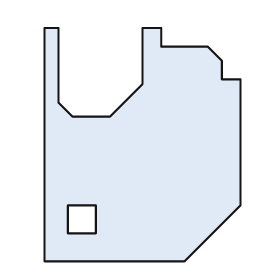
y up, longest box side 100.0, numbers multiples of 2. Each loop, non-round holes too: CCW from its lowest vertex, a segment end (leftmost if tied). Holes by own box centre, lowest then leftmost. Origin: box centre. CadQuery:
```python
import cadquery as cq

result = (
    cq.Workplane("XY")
    .moveTo(-42.0, -50.0)
    .lineTo(18.0, -50.0)
    .lineTo(42.0, -26.0)
    .lineTo(42.0, 28.0)
    .lineTo(34.0, 28.0)
    .lineTo(34.0, 36.0)
    .lineTo(28.0, 42.0)
    .lineTo(8.0, 42.0)
    .lineTo(8.0, 50.0)
    .lineTo(0.0, 50.0)
    .lineTo(0.0, 26.0)
    .lineTo(-14.0, 12.0)
    .lineTo(-30.0, 12.0)
    .lineTo(-36.0, 18.0)
    .lineTo(-36.0, 50.0)
    .lineTo(-42.0, 50.0)
    .close()
    .moveTo(-32.0, -38.0)
    .lineTo(-20.0, -38.0)
    .lineTo(-20.0, -26.0)
    .lineTo(-32.0, -26.0)
    .close()
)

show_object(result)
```